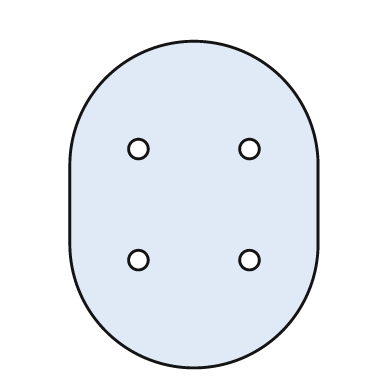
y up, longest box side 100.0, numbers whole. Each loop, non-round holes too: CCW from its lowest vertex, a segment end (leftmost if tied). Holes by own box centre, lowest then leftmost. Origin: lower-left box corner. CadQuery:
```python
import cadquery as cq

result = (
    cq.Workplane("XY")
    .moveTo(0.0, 38.0)
    .threePointArc((38.0, 0.0), (76.0, 38.0))
    .lineTo(76.0, 62.0)
    .threePointArc((38.0, 100.0), (0.0, 62.0))
    .close()
    .moveTo(21.0, 33.0)
    .circle(3.0)
    .moveTo(55.0, 33.0)
    .circle(3.0)
    .moveTo(21.0, 67.0)
    .circle(3.0)
    .moveTo(55.0, 67.0)
    .circle(3.0)
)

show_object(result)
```